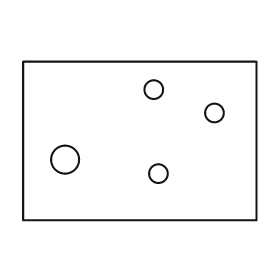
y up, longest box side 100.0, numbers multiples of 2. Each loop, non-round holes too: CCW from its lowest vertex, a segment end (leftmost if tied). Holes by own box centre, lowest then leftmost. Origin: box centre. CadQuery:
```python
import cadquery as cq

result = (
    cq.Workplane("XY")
    .moveTo(-50.0, -34.0)
    .lineTo(50.0, -34.0)
    .lineTo(50.0, 34.0)
    .lineTo(-50.0, 34.0)
    .close()
    .moveTo(8.0, -14.0)
    .circle(4.0)
    .moveTo(-32.0, -8.0)
    .circle(6.0)
    .moveTo(32.0, 12.0)
    .circle(4.0)
    .moveTo(6.0, 22.0)
    .circle(4.0)
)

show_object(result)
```